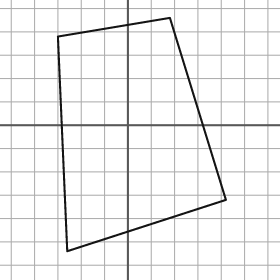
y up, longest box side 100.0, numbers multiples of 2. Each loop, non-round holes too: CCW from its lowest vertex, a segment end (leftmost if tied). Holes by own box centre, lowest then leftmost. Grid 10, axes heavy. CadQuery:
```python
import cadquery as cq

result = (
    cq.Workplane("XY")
    .moveTo(-26.0, -54.0)
    .lineTo(42.0, -32.0)
    .lineTo(18.0, 46.0)
    .lineTo(-30.0, 38.0)
    .close()
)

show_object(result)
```